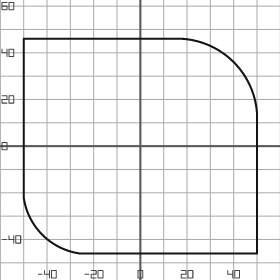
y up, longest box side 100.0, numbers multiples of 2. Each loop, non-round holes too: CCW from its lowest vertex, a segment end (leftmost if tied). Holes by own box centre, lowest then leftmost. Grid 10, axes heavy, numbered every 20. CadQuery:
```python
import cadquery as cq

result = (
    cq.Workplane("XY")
    .moveTo(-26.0, -46.0)
    .lineTo(50.0, -46.0)
    .lineTo(50.0, 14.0)
    .threePointArc((40.0, 36.0), (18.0, 46.0))
    .lineTo(-50.0, 46.0)
    .lineTo(-50.0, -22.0)
    .threePointArc((-42.0, -38.0), (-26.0, -46.0))
    .close()
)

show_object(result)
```